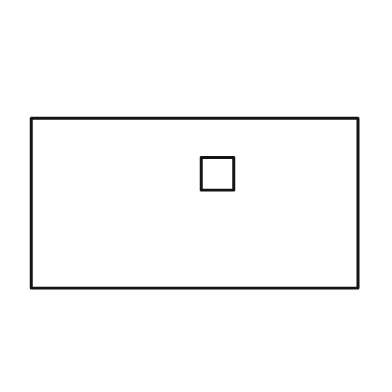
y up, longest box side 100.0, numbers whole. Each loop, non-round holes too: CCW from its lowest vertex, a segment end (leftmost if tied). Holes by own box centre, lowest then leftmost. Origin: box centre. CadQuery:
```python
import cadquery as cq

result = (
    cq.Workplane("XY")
    .moveTo(-50.0, -26.0)
    .lineTo(50.0, -26.0)
    .lineTo(50.0, 26.0)
    .lineTo(-50.0, 26.0)
    .close()
    .moveTo(2.0, 4.0)
    .lineTo(12.0, 4.0)
    .lineTo(12.0, 14.0)
    .lineTo(2.0, 14.0)
    .close()
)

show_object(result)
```